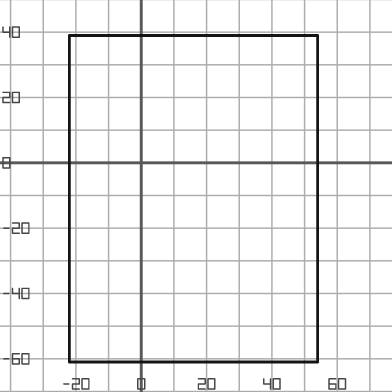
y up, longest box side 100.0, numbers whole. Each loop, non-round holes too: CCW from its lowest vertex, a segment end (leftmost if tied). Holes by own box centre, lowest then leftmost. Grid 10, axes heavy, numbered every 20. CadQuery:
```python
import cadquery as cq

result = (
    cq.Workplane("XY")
    .moveTo(-22.0, -61.0)
    .lineTo(54.0, -61.0)
    .lineTo(54.0, 39.0)
    .lineTo(-22.0, 39.0)
    .close()
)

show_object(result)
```